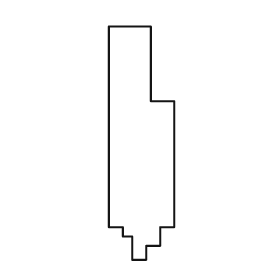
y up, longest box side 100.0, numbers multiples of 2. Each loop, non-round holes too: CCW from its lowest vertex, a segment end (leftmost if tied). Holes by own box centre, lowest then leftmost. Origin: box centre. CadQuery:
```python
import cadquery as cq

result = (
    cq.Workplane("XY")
    .moveTo(-4.0, -50.0)
    .lineTo(2.0, -50.0)
    .lineTo(2.0, -44.0)
    .lineTo(8.0, -44.0)
    .lineTo(8.0, -36.0)
    .lineTo(14.0, -36.0)
    .lineTo(14.0, 18.0)
    .lineTo(4.0, 18.0)
    .lineTo(4.0, 50.0)
    .lineTo(-14.0, 50.0)
    .lineTo(-14.0, -36.0)
    .lineTo(-8.0, -36.0)
    .lineTo(-8.0, -40.0)
    .lineTo(-4.0, -40.0)
    .close()
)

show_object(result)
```